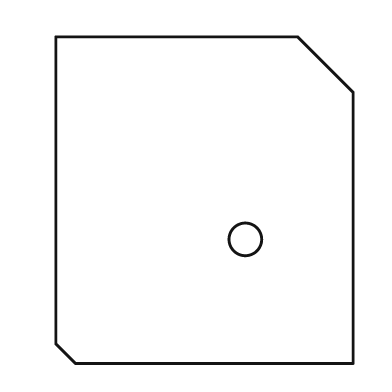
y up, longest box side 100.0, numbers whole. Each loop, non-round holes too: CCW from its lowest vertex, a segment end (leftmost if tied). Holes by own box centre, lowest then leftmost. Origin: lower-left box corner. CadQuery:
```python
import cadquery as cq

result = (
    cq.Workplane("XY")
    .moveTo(6.0, 0.0)
    .lineTo(91.0, 0.0)
    .lineTo(91.0, 83.0)
    .lineTo(74.0, 100.0)
    .lineTo(0.0, 100.0)
    .lineTo(0.0, 6.0)
    .close()
    .moveTo(58.0, 38.0)
    .circle(5.0)
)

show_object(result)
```